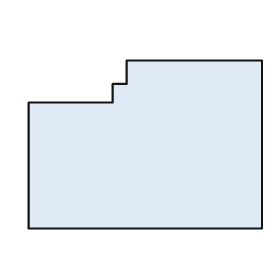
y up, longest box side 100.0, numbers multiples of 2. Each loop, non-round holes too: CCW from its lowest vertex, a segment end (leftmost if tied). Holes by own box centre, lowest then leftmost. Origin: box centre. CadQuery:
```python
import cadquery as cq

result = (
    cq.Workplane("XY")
    .moveTo(-50.0, -36.0)
    .lineTo(50.0, -36.0)
    .lineTo(50.0, 36.0)
    .lineTo(-8.0, 36.0)
    .lineTo(-8.0, 26.0)
    .lineTo(-14.0, 26.0)
    .lineTo(-14.0, 18.0)
    .lineTo(-50.0, 18.0)
    .close()
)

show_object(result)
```